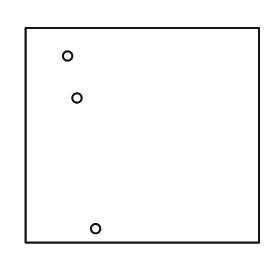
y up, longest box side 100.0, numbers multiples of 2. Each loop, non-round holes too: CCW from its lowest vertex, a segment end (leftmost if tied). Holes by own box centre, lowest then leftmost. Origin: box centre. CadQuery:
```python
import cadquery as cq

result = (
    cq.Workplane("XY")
    .moveTo(-50.0, -46.0)
    .lineTo(50.0, -46.0)
    .lineTo(50.0, 46.0)
    .lineTo(-50.0, 46.0)
    .close()
    .moveTo(-20.0, -40.0)
    .circle(2.0)
    .moveTo(-28.0, 16.0)
    .circle(2.0)
    .moveTo(-32.0, 34.0)
    .circle(2.0)
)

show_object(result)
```